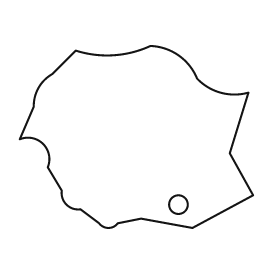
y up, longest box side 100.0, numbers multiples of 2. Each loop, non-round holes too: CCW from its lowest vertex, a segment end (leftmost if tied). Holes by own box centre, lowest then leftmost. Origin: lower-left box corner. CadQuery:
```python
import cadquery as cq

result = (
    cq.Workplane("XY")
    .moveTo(74.0, 0.0)
    .lineTo(100.0, 14.0)
    .lineTo(90.0, 32.0)
    .lineTo(98.0, 58.0)
    .threePointArc((86.0, 58.0), (76.0, 64.0))
    .threePointArc((68.0, 74.0), (56.0, 78.0))
    .threePointArc((40.0, 74.0), (24.0, 76.0))
    .lineTo(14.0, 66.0)
    .threePointArc((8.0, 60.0), (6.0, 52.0))
    .lineTo(0.0, 38.0)
    .threePointArc((10.0, 36.0), (12.0, 26.0))
    .lineTo(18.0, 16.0)
    .threePointArc((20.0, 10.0), (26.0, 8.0))
    .lineTo(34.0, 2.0)
    .threePointArc((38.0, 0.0), (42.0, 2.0))
    .lineTo(52.0, 4.0)
    .close()
    .moveTo(68.0, 10.0)
    .circle(4.0)
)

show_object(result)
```